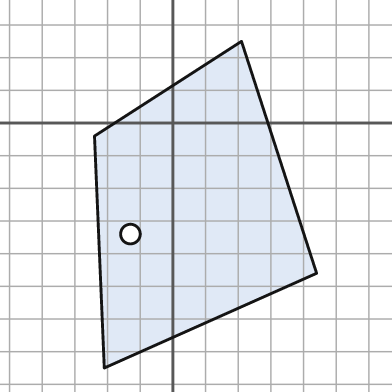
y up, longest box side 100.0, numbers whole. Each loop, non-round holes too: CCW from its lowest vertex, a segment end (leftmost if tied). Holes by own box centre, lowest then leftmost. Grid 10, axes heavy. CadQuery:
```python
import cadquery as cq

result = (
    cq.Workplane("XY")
    .moveTo(-21.0, -75.0)
    .lineTo(44.0, -46.0)
    .lineTo(21.0, 25.0)
    .lineTo(-24.0, -4.0)
    .close()
    .moveTo(-13.0, -34.0)
    .circle(3.0)
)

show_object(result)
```